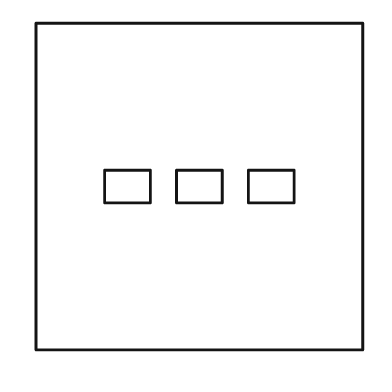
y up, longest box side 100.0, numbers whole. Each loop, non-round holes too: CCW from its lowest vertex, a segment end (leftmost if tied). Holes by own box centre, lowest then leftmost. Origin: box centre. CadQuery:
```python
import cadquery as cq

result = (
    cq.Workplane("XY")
    .moveTo(-50.0, -50.0)
    .lineTo(50.0, -50.0)
    .lineTo(50.0, 50.0)
    .lineTo(-50.0, 50.0)
    .close()
    .moveTo(-29.0, -5.0)
    .lineTo(-15.0, -5.0)
    .lineTo(-15.0, 5.0)
    .lineTo(-29.0, 5.0)
    .close()
    .moveTo(-7.0, -5.0)
    .lineTo(7.0, -5.0)
    .lineTo(7.0, 5.0)
    .lineTo(-7.0, 5.0)
    .close()
    .moveTo(15.0, -5.0)
    .lineTo(29.0, -5.0)
    .lineTo(29.0, 5.0)
    .lineTo(15.0, 5.0)
    .close()
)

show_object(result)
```